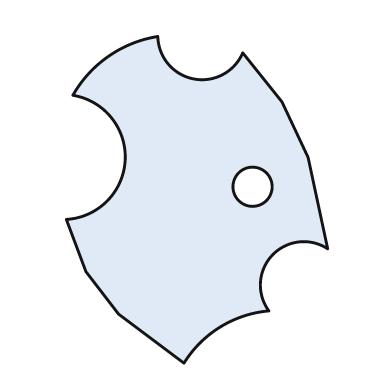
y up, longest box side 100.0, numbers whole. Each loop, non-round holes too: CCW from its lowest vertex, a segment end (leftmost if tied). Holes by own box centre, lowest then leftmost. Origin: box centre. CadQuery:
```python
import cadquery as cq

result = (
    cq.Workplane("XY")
    .moveTo(-4.0, -50.0)
    .threePointArc((7.0, -39.0), (22.0, -34.0))
    .threePointArc((23.0, -17.0), (40.0, -15.0))
    .lineTo(34.0, 13.0)
    .lineTo(26.0, 30.0)
    .lineTo(14.0, 45.0)
    .threePointArc((-1.0, 37.0), (-12.0, 50.0))
    .threePointArc((-27.0, 44.0), (-38.0, 32.0))
    .threePointArc((-22.0, 12.0), (-40.0, -6.0))
    .lineTo(-34.0, -22.0)
    .lineTo(-24.0, -35.0)
    .close()
    .moveTo(17.0, 4.0)
    .circle(6.0)
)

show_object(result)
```